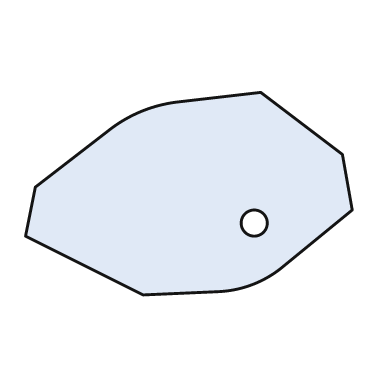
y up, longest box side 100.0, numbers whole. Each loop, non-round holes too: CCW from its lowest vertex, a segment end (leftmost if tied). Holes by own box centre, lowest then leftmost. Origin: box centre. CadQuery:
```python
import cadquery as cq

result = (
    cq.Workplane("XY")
    .moveTo(-14.0, -31.0)
    .lineTo(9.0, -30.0)
    .threePointArc((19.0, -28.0), (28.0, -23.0))
    .lineTo(50.0, -5.0)
    .lineTo(47.0, 12.0)
    .lineTo(22.0, 31.0)
    .lineTo(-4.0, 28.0)
    .threePointArc((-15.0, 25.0), (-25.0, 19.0))
    .lineTo(-47.0, 2.0)
    .lineTo(-50.0, -13.0)
    .close()
    .moveTo(20.0, -9.0)
    .circle(4.0)
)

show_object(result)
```